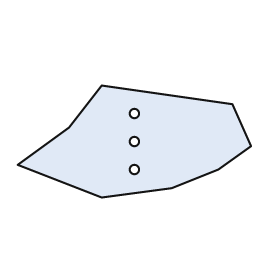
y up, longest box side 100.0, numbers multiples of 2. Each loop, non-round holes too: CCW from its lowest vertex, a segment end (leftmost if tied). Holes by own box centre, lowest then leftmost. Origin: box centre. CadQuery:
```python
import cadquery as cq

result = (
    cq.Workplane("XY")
    .moveTo(-14.0, -24.0)
    .lineTo(16.0, -20.0)
    .lineTo(36.0, -12.0)
    .lineTo(50.0, -2.0)
    .lineTo(42.0, 16.0)
    .lineTo(-14.0, 24.0)
    .lineTo(-28.0, 6.0)
    .lineTo(-50.0, -10.0)
    .close()
    .moveTo(0.0, -12.0)
    .circle(2.0)
    .moveTo(0.0, 0.0)
    .circle(2.0)
    .moveTo(0.0, 12.0)
    .circle(2.0)
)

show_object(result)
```